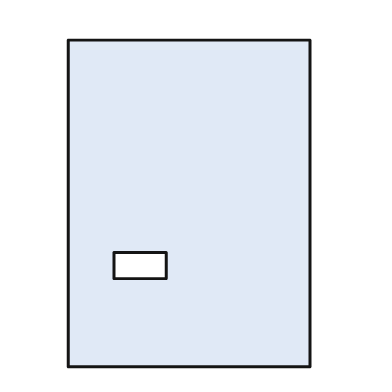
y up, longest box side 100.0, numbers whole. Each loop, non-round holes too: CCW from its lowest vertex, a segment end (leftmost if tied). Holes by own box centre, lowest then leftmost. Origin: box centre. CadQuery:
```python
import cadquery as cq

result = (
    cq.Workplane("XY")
    .moveTo(-37.0, -50.0)
    .lineTo(37.0, -50.0)
    .lineTo(37.0, 50.0)
    .lineTo(-37.0, 50.0)
    .close()
    .moveTo(-23.0, -23.0)
    .lineTo(-7.0, -23.0)
    .lineTo(-7.0, -15.0)
    .lineTo(-23.0, -15.0)
    .close()
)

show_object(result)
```